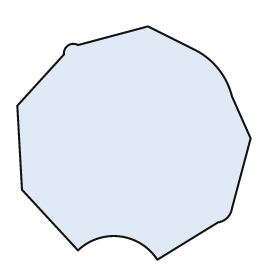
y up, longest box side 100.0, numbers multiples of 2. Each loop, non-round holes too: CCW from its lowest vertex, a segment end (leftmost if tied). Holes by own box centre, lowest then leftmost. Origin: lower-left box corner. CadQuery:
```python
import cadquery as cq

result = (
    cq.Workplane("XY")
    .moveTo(60.0, 0.0)
    .lineTo(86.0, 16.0)
    .threePointArc((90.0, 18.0), (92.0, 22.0))
    .lineTo(100.0, 52.0)
    .lineTo(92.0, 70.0)
    .threePointArc((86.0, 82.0), (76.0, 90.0))
    .lineTo(56.0, 100.0)
    .lineTo(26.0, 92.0)
    .threePointArc((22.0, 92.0), (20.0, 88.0))
    .lineTo(0.0, 66.0)
    .lineTo(2.0, 30.0)
    .lineTo(26.0, 4.0)
    .threePointArc((44.0, 10.0), (60.0, 0.0))
    .close()
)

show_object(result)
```